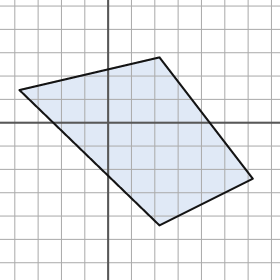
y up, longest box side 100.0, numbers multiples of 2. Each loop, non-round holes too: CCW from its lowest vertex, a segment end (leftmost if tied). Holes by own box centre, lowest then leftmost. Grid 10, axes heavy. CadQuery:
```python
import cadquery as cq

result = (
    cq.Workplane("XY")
    .moveTo(22.0, -44.0)
    .lineTo(62.0, -24.0)
    .lineTo(22.0, 28.0)
    .lineTo(-38.0, 14.0)
    .close()
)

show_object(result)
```